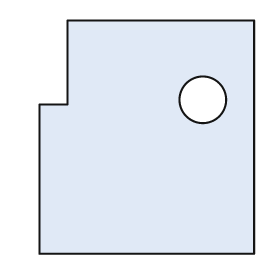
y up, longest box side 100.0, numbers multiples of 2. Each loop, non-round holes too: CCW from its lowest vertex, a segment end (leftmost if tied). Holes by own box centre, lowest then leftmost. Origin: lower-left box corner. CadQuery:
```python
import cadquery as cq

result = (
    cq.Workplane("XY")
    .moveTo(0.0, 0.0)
    .lineTo(92.0, 0.0)
    .lineTo(92.0, 100.0)
    .lineTo(12.0, 100.0)
    .lineTo(12.0, 64.0)
    .lineTo(0.0, 64.0)
    .close()
    .moveTo(70.0, 66.0)
    .circle(10.0)
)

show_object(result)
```